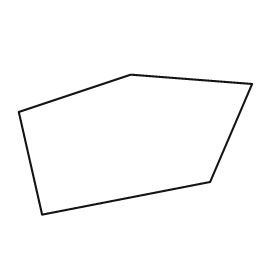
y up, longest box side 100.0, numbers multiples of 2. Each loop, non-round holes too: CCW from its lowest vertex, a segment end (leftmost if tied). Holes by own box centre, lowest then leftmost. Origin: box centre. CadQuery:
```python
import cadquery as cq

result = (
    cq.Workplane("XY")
    .moveTo(-40.0, -30.0)
    .lineTo(32.0, -16.0)
    .lineTo(50.0, 26.0)
    .lineTo(-2.0, 30.0)
    .lineTo(-50.0, 14.0)
    .close()
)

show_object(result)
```